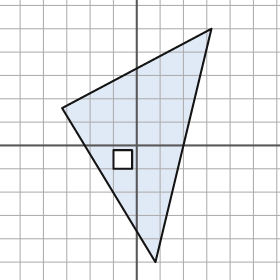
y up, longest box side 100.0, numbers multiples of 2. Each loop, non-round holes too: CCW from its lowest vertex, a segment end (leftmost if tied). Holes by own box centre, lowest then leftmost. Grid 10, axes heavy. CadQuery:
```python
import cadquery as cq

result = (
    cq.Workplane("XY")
    .moveTo(8.0, -50.0)
    .lineTo(32.0, 50.0)
    .lineTo(-32.0, 16.0)
    .close()
    .moveTo(-10.0, -10.0)
    .lineTo(-2.0, -10.0)
    .lineTo(-2.0, -2.0)
    .lineTo(-10.0, -2.0)
    .close()
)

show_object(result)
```